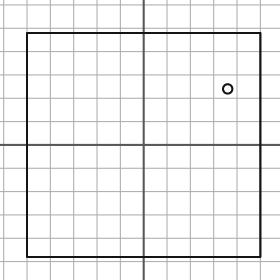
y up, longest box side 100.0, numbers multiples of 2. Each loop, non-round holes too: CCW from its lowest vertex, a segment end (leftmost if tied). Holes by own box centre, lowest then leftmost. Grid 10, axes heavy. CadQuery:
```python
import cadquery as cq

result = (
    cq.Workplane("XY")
    .moveTo(-50.0, -48.0)
    .lineTo(50.0, -48.0)
    .lineTo(50.0, 48.0)
    .lineTo(-50.0, 48.0)
    .close()
    .moveTo(36.0, 24.0)
    .circle(2.0)
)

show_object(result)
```